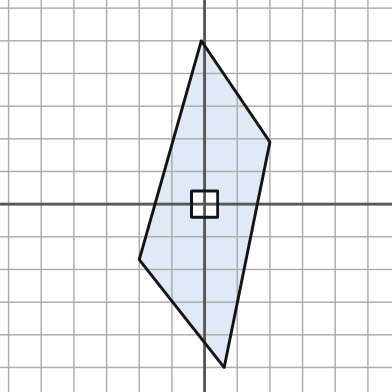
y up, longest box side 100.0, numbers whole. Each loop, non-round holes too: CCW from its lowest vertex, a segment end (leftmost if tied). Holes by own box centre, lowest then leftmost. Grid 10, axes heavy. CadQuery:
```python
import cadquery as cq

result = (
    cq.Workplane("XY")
    .moveTo(6.0, -50.0)
    .lineTo(20.0, 19.0)
    .lineTo(-1.0, 50.0)
    .lineTo(-20.0, -17.0)
    .close()
    .moveTo(-4.0, -4.0)
    .lineTo(4.0, -4.0)
    .lineTo(4.0, 4.0)
    .lineTo(-4.0, 4.0)
    .close()
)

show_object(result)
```